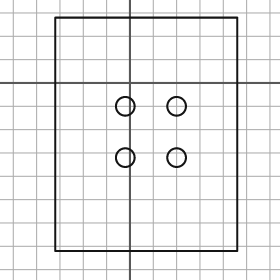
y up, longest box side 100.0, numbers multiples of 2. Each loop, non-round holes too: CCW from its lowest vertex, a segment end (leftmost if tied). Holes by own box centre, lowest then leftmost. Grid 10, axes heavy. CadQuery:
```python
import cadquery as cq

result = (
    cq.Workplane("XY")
    .moveTo(-32.0, -72.0)
    .lineTo(46.0, -72.0)
    .lineTo(46.0, 28.0)
    .lineTo(-32.0, 28.0)
    .close()
    .moveTo(-2.0, -32.0)
    .circle(4.0)
    .moveTo(20.0, -32.0)
    .circle(4.0)
    .moveTo(-2.0, -10.0)
    .circle(4.0)
    .moveTo(20.0, -10.0)
    .circle(4.0)
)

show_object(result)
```